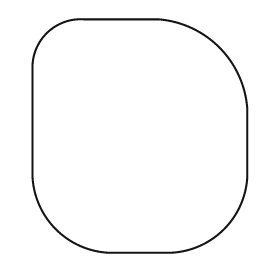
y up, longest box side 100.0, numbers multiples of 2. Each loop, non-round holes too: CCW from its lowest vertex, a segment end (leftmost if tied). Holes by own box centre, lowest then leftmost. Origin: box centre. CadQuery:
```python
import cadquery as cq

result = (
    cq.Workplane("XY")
    .moveTo(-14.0, -50.0)
    .lineTo(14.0, -50.0)
    .threePointArc((36.0, -40.0), (46.0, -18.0))
    .lineTo(46.0, 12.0)
    .threePointArc((34.0, 38.0), (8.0, 50.0))
    .lineTo(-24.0, 50.0)
    .threePointArc((-40.0, 44.0), (-46.0, 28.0))
    .lineTo(-46.0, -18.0)
    .threePointArc((-36.0, -40.0), (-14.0, -50.0))
    .close()
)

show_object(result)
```